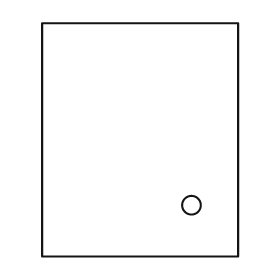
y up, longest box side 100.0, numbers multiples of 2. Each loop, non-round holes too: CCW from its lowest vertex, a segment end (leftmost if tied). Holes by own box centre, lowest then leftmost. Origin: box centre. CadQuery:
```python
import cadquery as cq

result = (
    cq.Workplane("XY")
    .moveTo(-42.0, -50.0)
    .lineTo(42.0, -50.0)
    .lineTo(42.0, 50.0)
    .lineTo(-42.0, 50.0)
    .close()
    .moveTo(22.0, -28.0)
    .circle(4.0)
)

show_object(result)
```